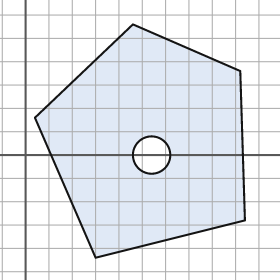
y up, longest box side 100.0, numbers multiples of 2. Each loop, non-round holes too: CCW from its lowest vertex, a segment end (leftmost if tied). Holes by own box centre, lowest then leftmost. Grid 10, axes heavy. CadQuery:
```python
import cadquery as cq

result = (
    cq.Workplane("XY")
    .moveTo(30.0, -44.0)
    .lineTo(94.0, -28.0)
    .lineTo(92.0, 36.0)
    .lineTo(46.0, 56.0)
    .lineTo(4.0, 16.0)
    .close()
    .moveTo(54.0, 0.0)
    .circle(8.0)
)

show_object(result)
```